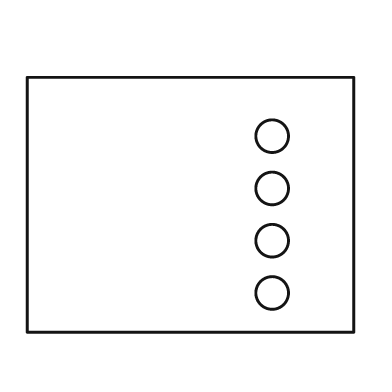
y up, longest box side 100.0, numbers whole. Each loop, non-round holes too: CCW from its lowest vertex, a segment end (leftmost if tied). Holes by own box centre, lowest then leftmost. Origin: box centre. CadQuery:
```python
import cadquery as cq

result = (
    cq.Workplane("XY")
    .moveTo(-50.0, -39.0)
    .lineTo(50.0, -39.0)
    .lineTo(50.0, 39.0)
    .lineTo(-50.0, 39.0)
    .close()
    .moveTo(25.0, -27.0)
    .circle(5.0)
    .moveTo(25.0, -11.0)
    .circle(5.0)
    .moveTo(25.0, 5.0)
    .circle(5.0)
    .moveTo(25.0, 21.0)
    .circle(5.0)
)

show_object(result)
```